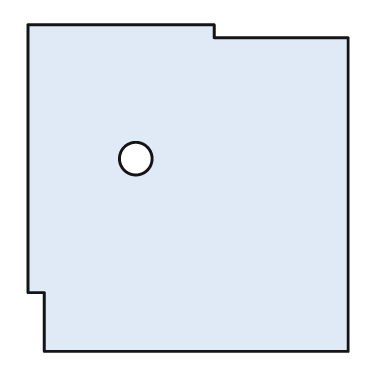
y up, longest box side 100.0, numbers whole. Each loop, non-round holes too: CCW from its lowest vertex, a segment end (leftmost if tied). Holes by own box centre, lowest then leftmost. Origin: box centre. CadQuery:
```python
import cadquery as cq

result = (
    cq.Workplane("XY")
    .moveTo(-44.0, -50.0)
    .lineTo(49.0, -50.0)
    .lineTo(49.0, 46.0)
    .lineTo(8.0, 46.0)
    .lineTo(8.0, 50.0)
    .lineTo(-49.0, 50.0)
    .lineTo(-49.0, -32.0)
    .lineTo(-44.0, -32.0)
    .close()
    .moveTo(-16.0, 9.0)
    .circle(5.0)
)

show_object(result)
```